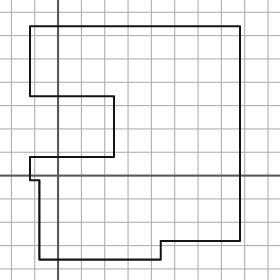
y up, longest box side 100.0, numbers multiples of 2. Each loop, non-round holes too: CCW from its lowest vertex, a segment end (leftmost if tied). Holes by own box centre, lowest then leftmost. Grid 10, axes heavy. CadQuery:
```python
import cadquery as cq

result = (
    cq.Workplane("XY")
    .moveTo(-8.0, -36.0)
    .lineTo(44.0, -36.0)
    .lineTo(44.0, -28.0)
    .lineTo(78.0, -28.0)
    .lineTo(78.0, 64.0)
    .lineTo(-12.0, 64.0)
    .lineTo(-12.0, 34.0)
    .lineTo(24.0, 34.0)
    .lineTo(24.0, 8.0)
    .lineTo(-12.0, 8.0)
    .lineTo(-12.0, -2.0)
    .lineTo(-8.0, -2.0)
    .close()
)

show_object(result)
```